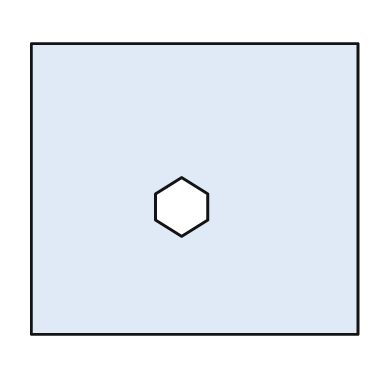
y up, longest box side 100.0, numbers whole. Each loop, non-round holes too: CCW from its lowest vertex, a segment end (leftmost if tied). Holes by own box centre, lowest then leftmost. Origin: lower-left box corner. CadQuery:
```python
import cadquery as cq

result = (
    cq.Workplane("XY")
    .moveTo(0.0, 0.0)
    .lineTo(100.0, 0.0)
    .lineTo(100.0, 89.0)
    .lineTo(0.0, 89.0)
    .close()
    .moveTo(46.0, 30.0)
    .lineTo(54.0, 35.0)
    .lineTo(54.0, 43.0)
    .lineTo(46.0, 48.0)
    .lineTo(38.0, 43.0)
    .lineTo(38.0, 35.0)
    .close()
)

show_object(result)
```